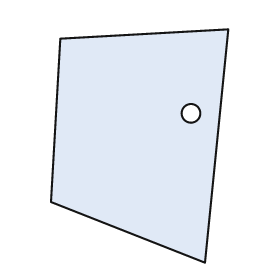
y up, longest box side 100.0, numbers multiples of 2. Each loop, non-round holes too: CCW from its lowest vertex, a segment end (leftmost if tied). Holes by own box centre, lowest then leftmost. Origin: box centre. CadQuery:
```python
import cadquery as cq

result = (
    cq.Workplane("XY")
    .moveTo(28.0, -50.0)
    .lineTo(38.0, 50.0)
    .lineTo(-34.0, 46.0)
    .lineTo(-38.0, -24.0)
    .close()
    .moveTo(22.0, 14.0)
    .circle(4.0)
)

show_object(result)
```